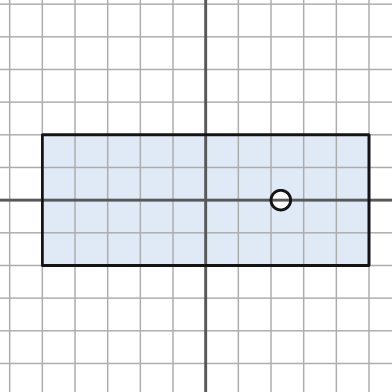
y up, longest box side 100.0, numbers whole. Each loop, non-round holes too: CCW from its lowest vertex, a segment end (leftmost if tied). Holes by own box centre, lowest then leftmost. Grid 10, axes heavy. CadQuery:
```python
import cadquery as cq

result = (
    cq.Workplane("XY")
    .moveTo(-50.0, -20.0)
    .lineTo(50.0, -20.0)
    .lineTo(50.0, 20.0)
    .lineTo(-50.0, 20.0)
    .close()
    .moveTo(23.0, 0.0)
    .circle(3.0)
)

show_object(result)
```